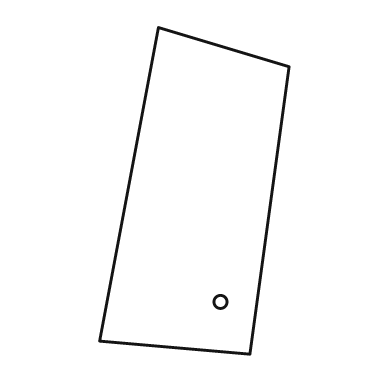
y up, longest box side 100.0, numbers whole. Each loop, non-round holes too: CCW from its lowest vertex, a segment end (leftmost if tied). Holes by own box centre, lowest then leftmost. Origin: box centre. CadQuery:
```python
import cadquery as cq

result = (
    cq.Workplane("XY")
    .moveTo(17.0, -50.0)
    .lineTo(29.0, 38.0)
    .lineTo(-11.0, 50.0)
    .lineTo(-29.0, -46.0)
    .close()
    .moveTo(8.0, -34.0)
    .circle(2.0)
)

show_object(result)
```